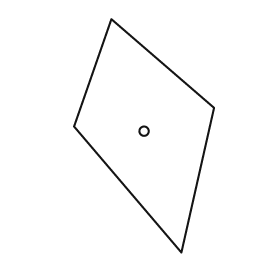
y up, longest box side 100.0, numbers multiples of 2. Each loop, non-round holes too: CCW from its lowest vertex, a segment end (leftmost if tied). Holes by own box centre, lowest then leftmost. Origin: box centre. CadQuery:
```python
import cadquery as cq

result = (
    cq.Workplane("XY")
    .moveTo(16.0, -50.0)
    .lineTo(30.0, 12.0)
    .lineTo(-14.0, 50.0)
    .lineTo(-30.0, 4.0)
    .close()
    .moveTo(0.0, 2.0)
    .circle(2.0)
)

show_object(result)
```